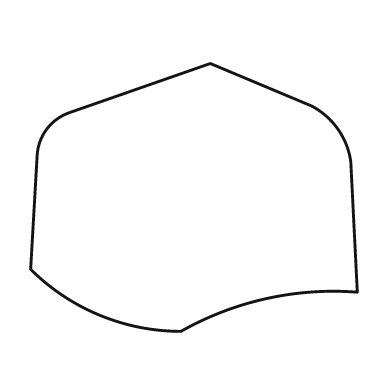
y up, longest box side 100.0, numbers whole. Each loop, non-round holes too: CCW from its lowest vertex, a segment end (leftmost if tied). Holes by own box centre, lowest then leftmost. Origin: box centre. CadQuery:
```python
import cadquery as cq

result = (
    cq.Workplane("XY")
    .moveTo(-4.0, -41.0)
    .threePointArc((22.0, -31.0), (50.0, -29.0))
    .lineTo(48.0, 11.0)
    .threePointArc((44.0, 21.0), (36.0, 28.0))
    .lineTo(5.0, 41.0)
    .lineTo(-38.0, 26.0)
    .threePointArc((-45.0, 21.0), (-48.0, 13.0))
    .lineTo(-50.0, -22.0)
    .threePointArc((-29.0, -36.0), (-4.0, -41.0))
    .close()
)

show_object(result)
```